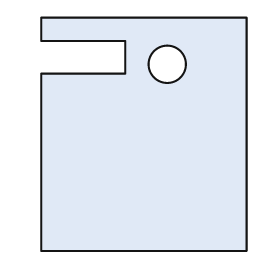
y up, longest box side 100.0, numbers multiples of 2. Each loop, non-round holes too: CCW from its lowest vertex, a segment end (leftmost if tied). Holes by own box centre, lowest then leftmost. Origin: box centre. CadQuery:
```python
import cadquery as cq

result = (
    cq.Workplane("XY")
    .moveTo(-44.0, -50.0)
    .lineTo(44.0, -50.0)
    .lineTo(44.0, 50.0)
    .lineTo(-44.0, 50.0)
    .lineTo(-44.0, 40.0)
    .lineTo(-8.0, 40.0)
    .lineTo(-8.0, 26.0)
    .lineTo(-44.0, 26.0)
    .close()
    .moveTo(10.0, 30.0)
    .circle(8.0)
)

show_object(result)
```